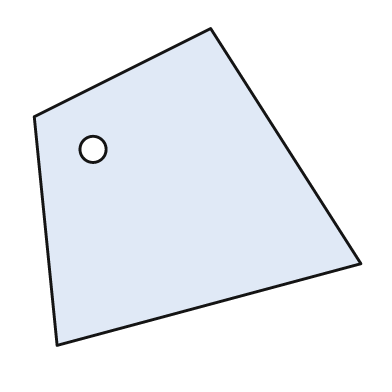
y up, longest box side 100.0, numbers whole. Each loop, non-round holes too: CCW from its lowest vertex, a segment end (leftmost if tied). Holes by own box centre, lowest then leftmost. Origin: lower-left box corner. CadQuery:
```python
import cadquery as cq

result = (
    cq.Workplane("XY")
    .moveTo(7.0, 0.0)
    .lineTo(100.0, 25.0)
    .lineTo(54.0, 97.0)
    .lineTo(0.0, 70.0)
    .close()
    .moveTo(18.0, 60.0)
    .circle(4.0)
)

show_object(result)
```